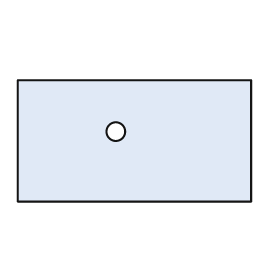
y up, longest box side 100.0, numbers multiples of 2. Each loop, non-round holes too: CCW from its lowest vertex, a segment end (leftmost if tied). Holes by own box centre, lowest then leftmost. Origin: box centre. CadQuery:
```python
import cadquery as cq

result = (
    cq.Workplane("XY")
    .moveTo(-50.0, -26.0)
    .lineTo(50.0, -26.0)
    .lineTo(50.0, 26.0)
    .lineTo(-50.0, 26.0)
    .close()
    .moveTo(-8.0, 4.0)
    .circle(4.0)
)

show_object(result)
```